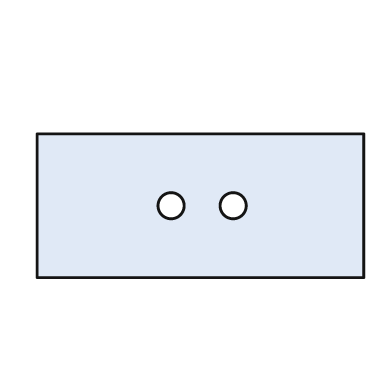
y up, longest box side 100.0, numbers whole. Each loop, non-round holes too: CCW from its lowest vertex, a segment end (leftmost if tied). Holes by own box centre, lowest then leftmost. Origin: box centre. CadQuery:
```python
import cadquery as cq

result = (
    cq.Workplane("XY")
    .moveTo(-50.0, -22.0)
    .lineTo(50.0, -22.0)
    .lineTo(50.0, 22.0)
    .lineTo(-50.0, 22.0)
    .close()
    .moveTo(-9.0, 0.0)
    .circle(4.0)
    .moveTo(10.0, 0.0)
    .circle(4.0)
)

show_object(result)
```